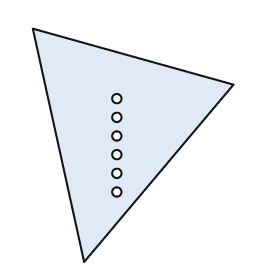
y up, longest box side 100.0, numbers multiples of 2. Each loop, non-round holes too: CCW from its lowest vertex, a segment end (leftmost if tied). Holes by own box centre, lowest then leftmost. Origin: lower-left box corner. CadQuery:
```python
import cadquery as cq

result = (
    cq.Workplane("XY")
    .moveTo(22.0, 0.0)
    .lineTo(86.0, 76.0)
    .lineTo(0.0, 100.0)
    .close()
    .moveTo(36.0, 30.0)
    .circle(2.0)
    .moveTo(36.0, 38.0)
    .circle(2.0)
    .moveTo(36.0, 46.0)
    .circle(2.0)
    .moveTo(36.0, 54.0)
    .circle(2.0)
    .moveTo(36.0, 62.0)
    .circle(2.0)
    .moveTo(36.0, 70.0)
    .circle(2.0)
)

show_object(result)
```